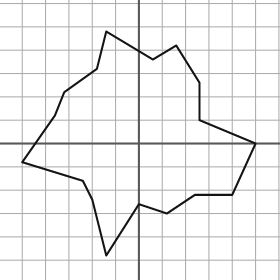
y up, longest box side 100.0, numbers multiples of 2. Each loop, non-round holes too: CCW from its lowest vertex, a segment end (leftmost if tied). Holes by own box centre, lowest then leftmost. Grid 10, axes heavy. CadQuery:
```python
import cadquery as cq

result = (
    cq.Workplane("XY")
    .moveTo(-14.0, -48.0)
    .lineTo(0.0, -26.0)
    .lineTo(12.0, -30.0)
    .lineTo(24.0, -22.0)
    .lineTo(40.0, -22.0)
    .lineTo(50.0, 0.0)
    .lineTo(26.0, 10.0)
    .lineTo(26.0, 26.0)
    .lineTo(16.0, 42.0)
    .lineTo(6.0, 36.0)
    .lineTo(-14.0, 48.0)
    .lineTo(-18.0, 32.0)
    .lineTo(-32.0, 22.0)
    .lineTo(-36.0, 12.0)
    .lineTo(-50.0, -8.0)
    .lineTo(-24.0, -16.0)
    .lineTo(-20.0, -24.0)
    .close()
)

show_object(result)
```